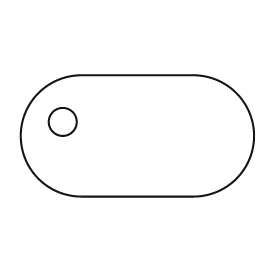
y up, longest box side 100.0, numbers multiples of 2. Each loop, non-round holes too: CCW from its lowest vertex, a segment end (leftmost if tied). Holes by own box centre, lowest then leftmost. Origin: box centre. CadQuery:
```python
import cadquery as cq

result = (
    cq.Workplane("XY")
    .moveTo(-24.0, -26.0)
    .lineTo(24.0, -26.0)
    .threePointArc((50.0, 0.0), (24.0, 26.0))
    .lineTo(-24.0, 26.0)
    .threePointArc((-50.0, 0.0), (-24.0, -26.0))
    .close()
    .moveTo(-32.0, 6.0)
    .circle(6.0)
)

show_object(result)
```